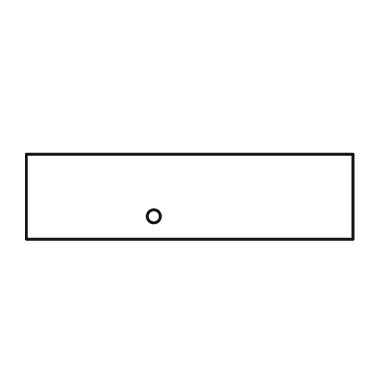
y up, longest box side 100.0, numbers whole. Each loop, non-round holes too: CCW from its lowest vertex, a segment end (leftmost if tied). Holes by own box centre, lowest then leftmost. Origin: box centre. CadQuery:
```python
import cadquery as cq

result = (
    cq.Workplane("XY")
    .moveTo(-50.0, -13.0)
    .lineTo(50.0, -13.0)
    .lineTo(50.0, 13.0)
    .lineTo(-50.0, 13.0)
    .close()
    .moveTo(-11.0, -6.0)
    .circle(2.0)
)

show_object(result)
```